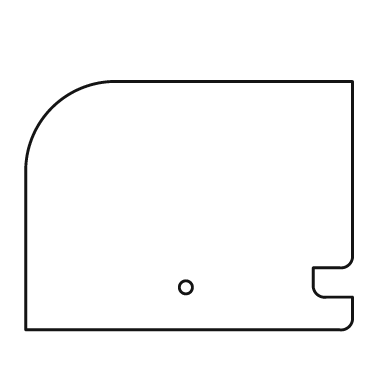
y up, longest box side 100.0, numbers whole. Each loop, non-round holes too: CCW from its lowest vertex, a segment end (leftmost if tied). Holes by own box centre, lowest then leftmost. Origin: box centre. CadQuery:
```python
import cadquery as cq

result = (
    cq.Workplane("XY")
    .moveTo(-50.0, -38.0)
    .lineTo(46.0, -38.0)
    .threePointArc((49.0, -37.0), (50.0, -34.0))
    .lineTo(50.0, -28.0)
    .lineTo(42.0, -28.0)
    .threePointArc((39.0, -27.0), (38.0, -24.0))
    .lineTo(38.0, -19.0)
    .lineTo(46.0, -19.0)
    .threePointArc((49.0, -18.0), (50.0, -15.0))
    .lineTo(50.0, 38.0)
    .lineTo(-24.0, 38.0)
    .threePointArc((-42.0, 30.0), (-50.0, 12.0))
    .close()
    .moveTo(-1.0, -25.0)
    .circle(2.0)
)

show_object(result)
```